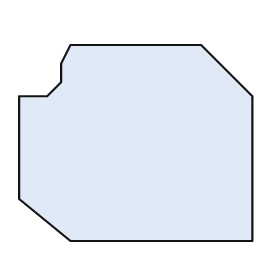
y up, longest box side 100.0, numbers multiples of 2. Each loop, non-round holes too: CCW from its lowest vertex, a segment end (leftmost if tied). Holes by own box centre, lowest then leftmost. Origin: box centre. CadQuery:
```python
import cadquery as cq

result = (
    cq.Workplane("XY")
    .moveTo(-28.0, -42.0)
    .lineTo(50.0, -42.0)
    .lineTo(50.0, 20.0)
    .lineTo(28.0, 42.0)
    .lineTo(-28.0, 42.0)
    .lineTo(-32.0, 34.0)
    .lineTo(-32.0, 26.0)
    .lineTo(-38.0, 20.0)
    .lineTo(-50.0, 20.0)
    .lineTo(-50.0, -24.0)
    .close()
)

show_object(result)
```